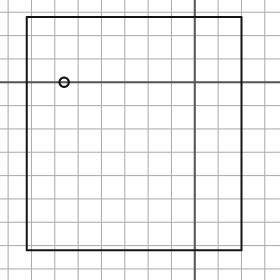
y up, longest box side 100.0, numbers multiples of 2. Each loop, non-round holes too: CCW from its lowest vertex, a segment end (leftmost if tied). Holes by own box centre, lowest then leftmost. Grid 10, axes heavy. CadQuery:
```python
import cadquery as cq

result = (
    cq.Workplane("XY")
    .moveTo(-72.0, -72.0)
    .lineTo(20.0, -72.0)
    .lineTo(20.0, 28.0)
    .lineTo(-72.0, 28.0)
    .close()
    .moveTo(-56.0, 0.0)
    .circle(2.0)
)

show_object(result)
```